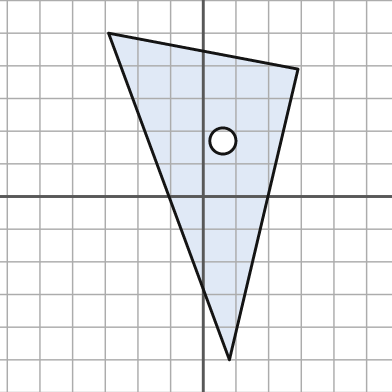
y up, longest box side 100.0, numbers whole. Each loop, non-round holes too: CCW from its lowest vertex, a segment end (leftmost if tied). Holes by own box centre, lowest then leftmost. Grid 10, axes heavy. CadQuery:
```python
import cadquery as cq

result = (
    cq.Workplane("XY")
    .moveTo(8.0, -50.0)
    .lineTo(29.0, 39.0)
    .lineTo(-29.0, 50.0)
    .close()
    .moveTo(6.0, 17.0)
    .circle(4.0)
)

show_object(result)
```